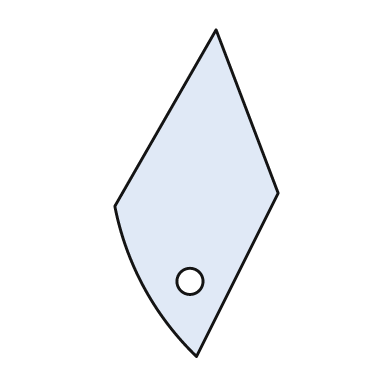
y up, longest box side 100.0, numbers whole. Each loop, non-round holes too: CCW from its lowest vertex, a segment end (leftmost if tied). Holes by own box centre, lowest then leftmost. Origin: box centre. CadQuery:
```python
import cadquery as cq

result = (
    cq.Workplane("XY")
    .moveTo(0.0, -50.0)
    .lineTo(25.0, 0.0)
    .lineTo(6.0, 50.0)
    .lineTo(-25.0, -4.0)
    .threePointArc((-16.0, -29.0), (0.0, -50.0))
    .close()
    .moveTo(-2.0, -27.0)
    .circle(4.0)
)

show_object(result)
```